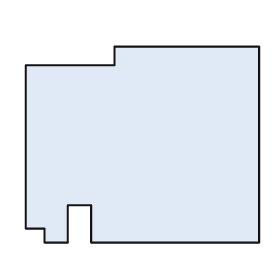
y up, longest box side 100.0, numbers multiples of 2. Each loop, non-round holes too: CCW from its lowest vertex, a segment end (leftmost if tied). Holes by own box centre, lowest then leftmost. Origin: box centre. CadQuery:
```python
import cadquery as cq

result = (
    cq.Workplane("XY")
    .moveTo(-42.0, -42.0)
    .lineTo(-32.0, -42.0)
    .lineTo(-32.0, -26.0)
    .lineTo(-22.0, -26.0)
    .lineTo(-22.0, -42.0)
    .lineTo(50.0, -42.0)
    .lineTo(50.0, 42.0)
    .lineTo(-12.0, 42.0)
    .lineTo(-12.0, 34.0)
    .lineTo(-50.0, 34.0)
    .lineTo(-50.0, -36.0)
    .lineTo(-42.0, -36.0)
    .close()
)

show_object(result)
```